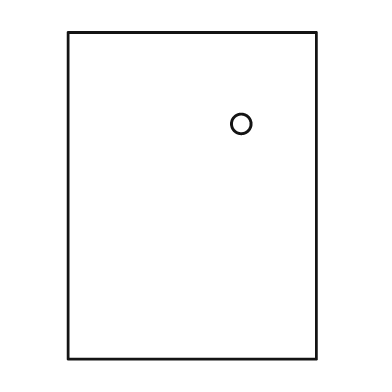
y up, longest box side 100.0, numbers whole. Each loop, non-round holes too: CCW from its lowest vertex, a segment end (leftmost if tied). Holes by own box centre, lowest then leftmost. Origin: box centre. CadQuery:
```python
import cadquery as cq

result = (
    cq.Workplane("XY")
    .moveTo(-38.0, -50.0)
    .lineTo(38.0, -50.0)
    .lineTo(38.0, 50.0)
    .lineTo(-38.0, 50.0)
    .close()
    .moveTo(15.0, 22.0)
    .circle(3.0)
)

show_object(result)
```